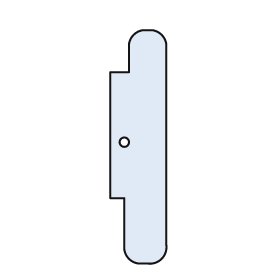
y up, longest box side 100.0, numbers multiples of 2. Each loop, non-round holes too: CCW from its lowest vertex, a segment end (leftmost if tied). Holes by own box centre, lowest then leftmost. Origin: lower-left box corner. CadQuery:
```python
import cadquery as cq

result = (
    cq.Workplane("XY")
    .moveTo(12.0, 0.0)
    .lineTo(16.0, 0.0)
    .threePointArc((22.0, 2.0), (24.0, 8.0))
    .lineTo(24.0, 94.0)
    .threePointArc((22.0, 98.0), (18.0, 100.0))
    .lineTo(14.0, 100.0)
    .threePointArc((10.0, 98.0), (8.0, 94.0))
    .lineTo(8.0, 82.0)
    .lineTo(0.0, 82.0)
    .lineTo(0.0, 28.0)
    .lineTo(6.0, 28.0)
    .lineTo(6.0, 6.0)
    .threePointArc((8.0, 2.0), (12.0, 0.0))
    .close()
    .moveTo(6.0, 52.0)
    .circle(2.0)
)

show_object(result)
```